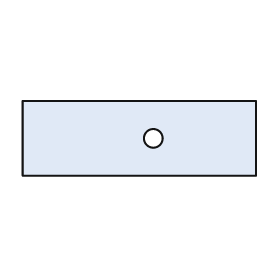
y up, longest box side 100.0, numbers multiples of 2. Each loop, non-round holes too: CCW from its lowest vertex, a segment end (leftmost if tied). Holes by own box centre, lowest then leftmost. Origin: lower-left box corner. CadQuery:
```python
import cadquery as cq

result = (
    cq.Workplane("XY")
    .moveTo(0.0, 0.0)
    .lineTo(100.0, 0.0)
    .lineTo(100.0, 32.0)
    .lineTo(0.0, 32.0)
    .close()
    .moveTo(56.0, 16.0)
    .circle(4.0)
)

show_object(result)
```